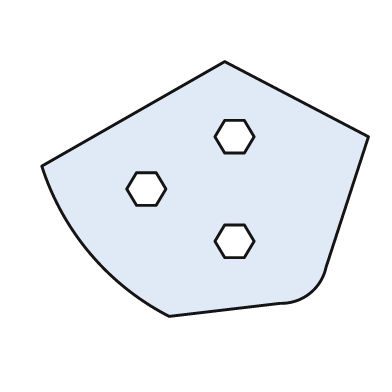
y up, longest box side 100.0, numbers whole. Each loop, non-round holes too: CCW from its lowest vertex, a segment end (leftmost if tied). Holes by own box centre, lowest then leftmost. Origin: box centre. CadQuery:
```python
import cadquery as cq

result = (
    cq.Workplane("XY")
    .moveTo(-11.0, -39.0)
    .lineTo(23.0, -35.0)
    .threePointArc((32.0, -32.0), (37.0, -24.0))
    .lineTo(50.0, 16.0)
    .lineTo(6.0, 39.0)
    .lineTo(-50.0, 7.0)
    .threePointArc((-35.0, -20.0), (-11.0, -39.0))
    .close()
    .moveTo(6.0, -21.0)
    .lineTo(12.0, -21.0)
    .lineTo(15.0, -16.0)
    .lineTo(12.0, -11.0)
    .lineTo(6.0, -11.0)
    .lineTo(3.0, -16.0)
    .close()
    .moveTo(-21.0, -5.0)
    .lineTo(-15.0, -5.0)
    .lineTo(-12.0, 0.0)
    .lineTo(-15.0, 5.0)
    .lineTo(-21.0, 5.0)
    .lineTo(-24.0, 0.0)
    .close()
    .moveTo(6.0, 11.0)
    .lineTo(12.0, 11.0)
    .lineTo(15.0, 16.0)
    .lineTo(12.0, 21.0)
    .lineTo(6.0, 21.0)
    .lineTo(3.0, 16.0)
    .close()
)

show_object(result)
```